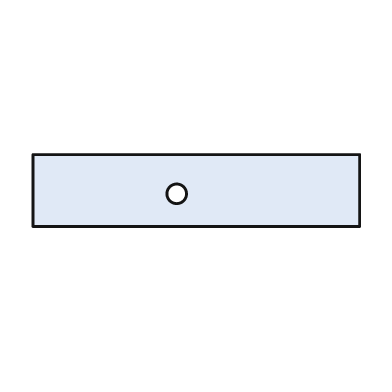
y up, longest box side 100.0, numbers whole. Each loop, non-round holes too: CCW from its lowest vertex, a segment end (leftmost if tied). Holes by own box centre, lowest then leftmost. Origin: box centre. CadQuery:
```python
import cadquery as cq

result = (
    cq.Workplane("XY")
    .moveTo(-50.0, -11.0)
    .lineTo(50.0, -11.0)
    .lineTo(50.0, 11.0)
    .lineTo(-50.0, 11.0)
    .close()
    .moveTo(-6.0, -1.0)
    .circle(3.0)
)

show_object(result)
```